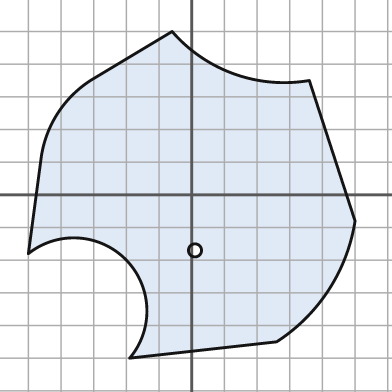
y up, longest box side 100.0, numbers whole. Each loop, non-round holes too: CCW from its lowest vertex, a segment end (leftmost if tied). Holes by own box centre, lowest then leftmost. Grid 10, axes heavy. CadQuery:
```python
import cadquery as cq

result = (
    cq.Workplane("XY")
    .moveTo(-19.0, -50.0)
    .lineTo(26.0, -45.0)
    .threePointArc((42.0, -29.0), (50.0, -8.0))
    .lineTo(36.0, 35.0)
    .threePointArc((13.0, 37.0), (-6.0, 50.0))
    .lineTo(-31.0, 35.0)
    .threePointArc((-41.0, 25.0), (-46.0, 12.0))
    .lineTo(-50.0, -18.0)
    .threePointArc((-20.0, -20.0), (-19.0, -50.0))
    .close()
    .moveTo(1.0, -17.0)
    .circle(2.0)
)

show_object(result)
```